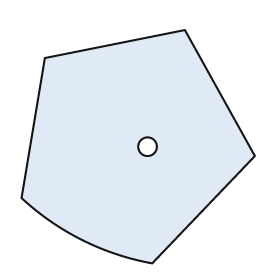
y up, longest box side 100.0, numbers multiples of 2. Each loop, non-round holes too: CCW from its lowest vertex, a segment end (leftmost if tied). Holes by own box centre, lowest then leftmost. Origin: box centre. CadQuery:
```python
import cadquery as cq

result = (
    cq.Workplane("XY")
    .moveTo(6.0, -50.0)
    .lineTo(50.0, -4.0)
    .lineTo(20.0, 50.0)
    .lineTo(-40.0, 38.0)
    .lineTo(-50.0, -22.0)
    .threePointArc((-24.0, -40.0), (6.0, -50.0))
    .close()
    .moveTo(4.0, 0.0)
    .circle(4.0)
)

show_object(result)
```